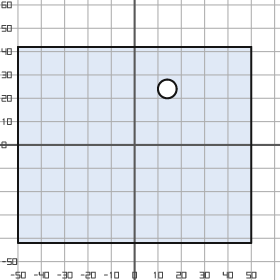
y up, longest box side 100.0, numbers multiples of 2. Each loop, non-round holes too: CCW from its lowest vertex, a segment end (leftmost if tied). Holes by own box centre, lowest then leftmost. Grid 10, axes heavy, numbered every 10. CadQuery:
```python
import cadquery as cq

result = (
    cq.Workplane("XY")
    .moveTo(-50.0, -42.0)
    .lineTo(50.0, -42.0)
    .lineTo(50.0, 42.0)
    .lineTo(-50.0, 42.0)
    .close()
    .moveTo(14.0, 24.0)
    .circle(4.0)
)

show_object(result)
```